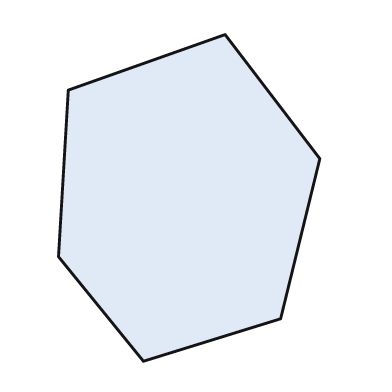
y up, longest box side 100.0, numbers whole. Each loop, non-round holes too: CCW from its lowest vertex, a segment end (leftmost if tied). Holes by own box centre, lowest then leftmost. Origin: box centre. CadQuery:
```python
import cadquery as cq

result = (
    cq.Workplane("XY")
    .moveTo(-14.0, -50.0)
    .lineTo(28.0, -37.0)
    .lineTo(40.0, 12.0)
    .lineTo(11.0, 50.0)
    .lineTo(-37.0, 33.0)
    .lineTo(-40.0, -18.0)
    .close()
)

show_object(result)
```